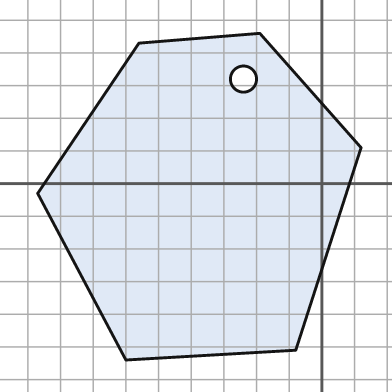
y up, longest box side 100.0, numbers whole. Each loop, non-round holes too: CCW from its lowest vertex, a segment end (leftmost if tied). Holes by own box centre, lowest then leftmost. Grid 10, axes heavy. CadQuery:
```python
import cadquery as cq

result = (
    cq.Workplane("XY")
    .moveTo(-60.0, -54.0)
    .lineTo(-8.0, -51.0)
    .lineTo(12.0, 11.0)
    .lineTo(-19.0, 46.0)
    .lineTo(-56.0, 43.0)
    .lineTo(-87.0, -3.0)
    .close()
    .moveTo(-24.0, 32.0)
    .circle(4.0)
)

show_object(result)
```